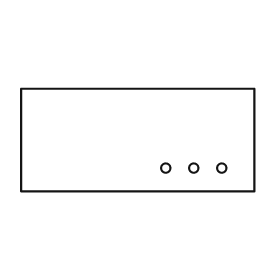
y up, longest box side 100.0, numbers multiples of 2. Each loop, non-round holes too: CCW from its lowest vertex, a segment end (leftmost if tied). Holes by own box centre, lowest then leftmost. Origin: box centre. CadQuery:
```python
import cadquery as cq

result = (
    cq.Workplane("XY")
    .moveTo(-50.0, -22.0)
    .lineTo(50.0, -22.0)
    .lineTo(50.0, 22.0)
    .lineTo(-50.0, 22.0)
    .close()
    .moveTo(12.0, -12.0)
    .circle(2.0)
    .moveTo(24.0, -12.0)
    .circle(2.0)
    .moveTo(36.0, -12.0)
    .circle(2.0)
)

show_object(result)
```